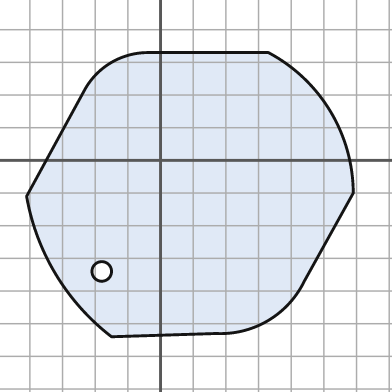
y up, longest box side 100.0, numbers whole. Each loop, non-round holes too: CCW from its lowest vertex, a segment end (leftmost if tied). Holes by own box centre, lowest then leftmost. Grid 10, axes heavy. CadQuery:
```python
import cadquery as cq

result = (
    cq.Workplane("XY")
    .moveTo(-15.0, -54.0)
    .lineTo(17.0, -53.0)
    .threePointArc((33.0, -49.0), (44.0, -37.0))
    .lineTo(59.0, -10.0)
    .threePointArc((52.0, 15.0), (33.0, 33.0))
    .lineTo(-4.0, 33.0)
    .threePointArc((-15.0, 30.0), (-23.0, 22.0))
    .lineTo(-41.0, -11.0)
    .threePointArc((-32.0, -35.0), (-15.0, -54.0))
    .close()
    .moveTo(-18.0, -34.0)
    .circle(3.0)
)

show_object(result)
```